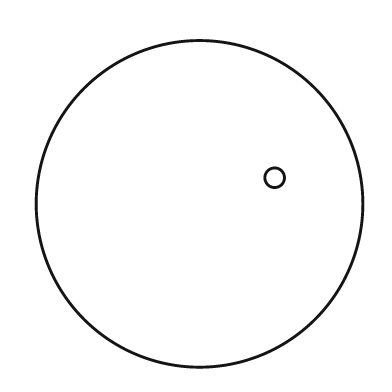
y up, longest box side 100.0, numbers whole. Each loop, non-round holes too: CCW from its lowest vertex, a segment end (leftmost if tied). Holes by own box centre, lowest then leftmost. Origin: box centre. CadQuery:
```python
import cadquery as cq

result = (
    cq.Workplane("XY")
    .moveTo(0.0, 0.0)
    .circle(50.0)
    .moveTo(23.0, 8.0)
    .circle(3.0)
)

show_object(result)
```